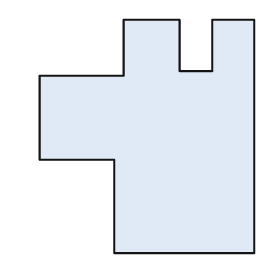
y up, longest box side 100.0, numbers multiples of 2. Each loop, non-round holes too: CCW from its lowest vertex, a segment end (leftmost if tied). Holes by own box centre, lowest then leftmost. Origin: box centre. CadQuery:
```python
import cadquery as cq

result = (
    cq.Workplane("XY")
    .moveTo(-14.0, -50.0)
    .lineTo(46.0, -50.0)
    .lineTo(46.0, 50.0)
    .lineTo(28.0, 50.0)
    .lineTo(28.0, 28.0)
    .lineTo(14.0, 28.0)
    .lineTo(14.0, 50.0)
    .lineTo(-10.0, 50.0)
    .lineTo(-10.0, 26.0)
    .lineTo(-46.0, 26.0)
    .lineTo(-46.0, -10.0)
    .lineTo(-14.0, -10.0)
    .close()
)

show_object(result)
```